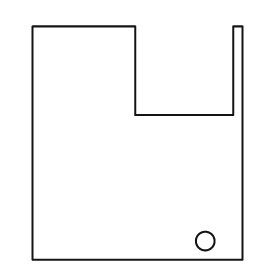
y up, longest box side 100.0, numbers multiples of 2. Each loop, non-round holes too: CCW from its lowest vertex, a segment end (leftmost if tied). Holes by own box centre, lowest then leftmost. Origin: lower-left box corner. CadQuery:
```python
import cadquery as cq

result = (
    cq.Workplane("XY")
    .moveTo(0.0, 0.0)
    .lineTo(90.0, 0.0)
    .lineTo(90.0, 100.0)
    .lineTo(86.0, 100.0)
    .lineTo(86.0, 62.0)
    .lineTo(44.0, 62.0)
    .lineTo(44.0, 100.0)
    .lineTo(0.0, 100.0)
    .close()
    .moveTo(74.0, 8.0)
    .circle(4.0)
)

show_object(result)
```